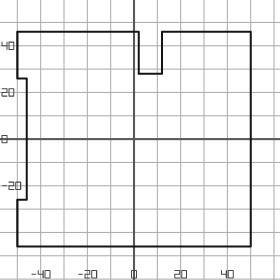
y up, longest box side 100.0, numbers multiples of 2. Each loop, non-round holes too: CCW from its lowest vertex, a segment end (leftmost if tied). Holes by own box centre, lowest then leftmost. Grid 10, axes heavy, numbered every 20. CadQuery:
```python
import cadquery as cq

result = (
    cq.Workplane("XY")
    .moveTo(-50.0, -46.0)
    .lineTo(50.0, -46.0)
    .lineTo(50.0, 46.0)
    .lineTo(12.0, 46.0)
    .lineTo(12.0, 28.0)
    .lineTo(2.0, 28.0)
    .lineTo(2.0, 46.0)
    .lineTo(-50.0, 46.0)
    .lineTo(-50.0, 26.0)
    .lineTo(-46.0, 26.0)
    .lineTo(-46.0, -26.0)
    .lineTo(-50.0, -26.0)
    .close()
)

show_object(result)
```